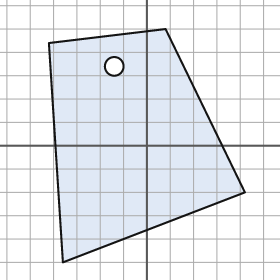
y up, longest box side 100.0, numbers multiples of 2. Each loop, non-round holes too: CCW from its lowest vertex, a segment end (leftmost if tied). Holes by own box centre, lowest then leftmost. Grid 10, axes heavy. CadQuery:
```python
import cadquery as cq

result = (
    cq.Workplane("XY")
    .moveTo(-36.0, -50.0)
    .lineTo(42.0, -20.0)
    .lineTo(8.0, 50.0)
    .lineTo(-42.0, 44.0)
    .close()
    .moveTo(-14.0, 34.0)
    .circle(4.0)
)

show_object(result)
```